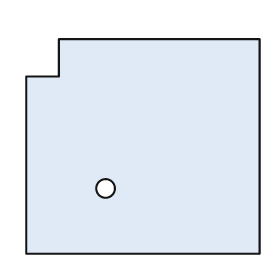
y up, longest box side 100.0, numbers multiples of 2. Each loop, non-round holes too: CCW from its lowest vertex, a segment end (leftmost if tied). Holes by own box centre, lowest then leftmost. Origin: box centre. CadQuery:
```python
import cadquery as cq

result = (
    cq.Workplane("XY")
    .moveTo(-50.0, -46.0)
    .lineTo(50.0, -46.0)
    .lineTo(50.0, 46.0)
    .lineTo(-36.0, 46.0)
    .lineTo(-36.0, 30.0)
    .lineTo(-50.0, 30.0)
    .close()
    .moveTo(-16.0, -18.0)
    .circle(4.0)
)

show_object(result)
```